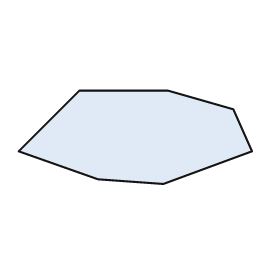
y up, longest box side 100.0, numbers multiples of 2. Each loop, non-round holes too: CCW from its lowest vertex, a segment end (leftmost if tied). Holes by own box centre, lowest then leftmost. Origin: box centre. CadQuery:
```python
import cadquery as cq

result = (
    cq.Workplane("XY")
    .moveTo(12.0, -20.0)
    .lineTo(50.0, -6.0)
    .lineTo(42.0, 12.0)
    .lineTo(14.0, 20.0)
    .lineTo(-24.0, 20.0)
    .lineTo(-50.0, -6.0)
    .lineTo(-16.0, -18.0)
    .close()
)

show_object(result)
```